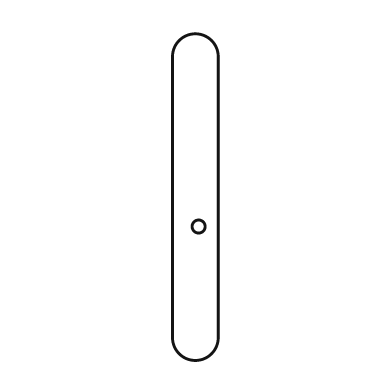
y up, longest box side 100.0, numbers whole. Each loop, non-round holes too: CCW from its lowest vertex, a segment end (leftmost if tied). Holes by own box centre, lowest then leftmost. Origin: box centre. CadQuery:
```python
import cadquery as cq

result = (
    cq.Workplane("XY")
    .moveTo(-7.0, -43.0)
    .threePointArc((0.0, -50.0), (7.0, -43.0))
    .lineTo(7.0, 43.0)
    .threePointArc((0.0, 50.0), (-7.0, 43.0))
    .close()
    .moveTo(1.0, -9.0)
    .circle(2.0)
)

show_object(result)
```